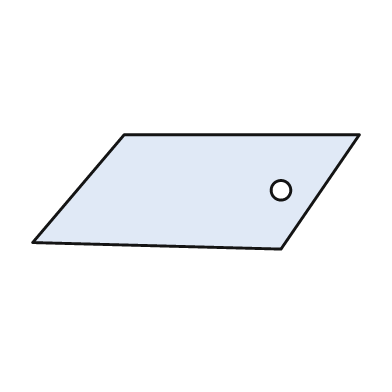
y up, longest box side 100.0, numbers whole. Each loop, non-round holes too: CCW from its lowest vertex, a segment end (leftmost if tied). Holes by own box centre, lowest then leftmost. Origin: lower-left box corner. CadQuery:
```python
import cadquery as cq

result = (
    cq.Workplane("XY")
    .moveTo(76.0, 0.0)
    .lineTo(100.0, 35.0)
    .lineTo(28.0, 35.0)
    .lineTo(0.0, 2.0)
    .close()
    .moveTo(76.0, 18.0)
    .circle(3.0)
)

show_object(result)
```